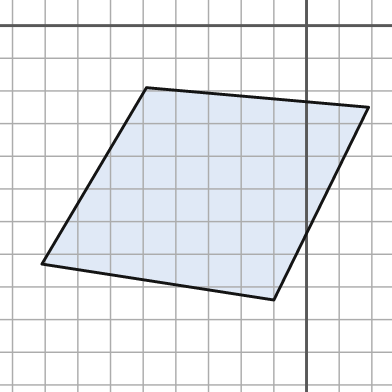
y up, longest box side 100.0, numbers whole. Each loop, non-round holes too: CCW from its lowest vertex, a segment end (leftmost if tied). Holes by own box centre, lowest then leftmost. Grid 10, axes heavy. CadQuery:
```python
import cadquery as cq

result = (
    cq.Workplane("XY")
    .moveTo(-10.0, -84.0)
    .lineTo(19.0, -25.0)
    .lineTo(-49.0, -19.0)
    .lineTo(-81.0, -73.0)
    .close()
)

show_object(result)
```